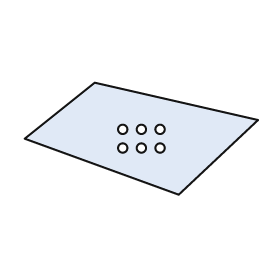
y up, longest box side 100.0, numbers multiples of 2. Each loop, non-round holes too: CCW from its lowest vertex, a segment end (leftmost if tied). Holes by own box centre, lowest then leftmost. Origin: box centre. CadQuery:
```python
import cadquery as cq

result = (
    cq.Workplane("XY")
    .moveTo(16.0, -24.0)
    .lineTo(50.0, 8.0)
    .lineTo(-20.0, 24.0)
    .lineTo(-50.0, 0.0)
    .close()
    .moveTo(-8.0, -4.0)
    .circle(2.0)
    .moveTo(0.0, -4.0)
    .circle(2.0)
    .moveTo(8.0, -4.0)
    .circle(2.0)
    .moveTo(-8.0, 4.0)
    .circle(2.0)
    .moveTo(0.0, 4.0)
    .circle(2.0)
    .moveTo(8.0, 4.0)
    .circle(2.0)
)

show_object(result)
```